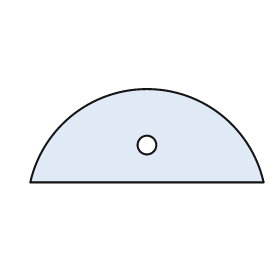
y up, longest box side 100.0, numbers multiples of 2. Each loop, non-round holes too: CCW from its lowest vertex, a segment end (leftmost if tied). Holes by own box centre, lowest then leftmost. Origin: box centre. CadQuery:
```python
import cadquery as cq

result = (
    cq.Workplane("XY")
    .moveTo(-50.0, -20.0)
    .lineTo(50.0, -20.0)
    .threePointArc((0.0, 20.0), (-50.0, -20.0))
    .close()
    .moveTo(0.0, -4.0)
    .circle(4.0)
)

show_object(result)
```